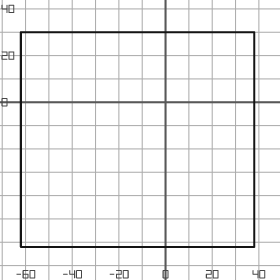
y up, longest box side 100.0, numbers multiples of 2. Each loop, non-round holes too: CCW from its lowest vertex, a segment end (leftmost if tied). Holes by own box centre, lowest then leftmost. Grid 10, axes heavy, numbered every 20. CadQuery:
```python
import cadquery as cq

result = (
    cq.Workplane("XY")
    .moveTo(-62.0, -62.0)
    .lineTo(38.0, -62.0)
    .lineTo(38.0, 30.0)
    .lineTo(-62.0, 30.0)
    .close()
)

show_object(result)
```